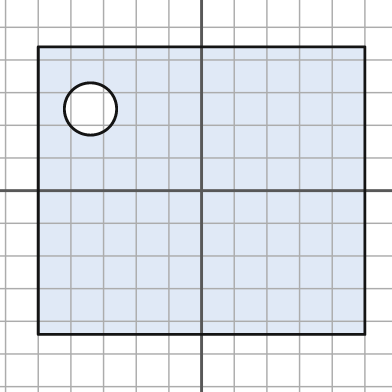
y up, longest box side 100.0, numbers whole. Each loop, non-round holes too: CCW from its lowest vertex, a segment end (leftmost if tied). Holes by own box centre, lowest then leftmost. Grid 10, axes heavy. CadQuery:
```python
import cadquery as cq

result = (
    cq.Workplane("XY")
    .moveTo(-50.0, -44.0)
    .lineTo(50.0, -44.0)
    .lineTo(50.0, 44.0)
    .lineTo(-50.0, 44.0)
    .close()
    .moveTo(-34.0, 25.0)
    .circle(8.0)
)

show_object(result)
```